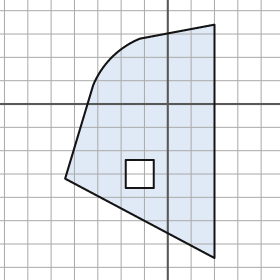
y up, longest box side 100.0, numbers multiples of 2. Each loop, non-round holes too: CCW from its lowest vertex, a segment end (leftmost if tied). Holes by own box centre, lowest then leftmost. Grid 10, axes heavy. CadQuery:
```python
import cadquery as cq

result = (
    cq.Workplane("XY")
    .moveTo(20.0, -66.0)
    .lineTo(20.0, 34.0)
    .lineTo(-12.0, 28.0)
    .threePointArc((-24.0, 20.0), (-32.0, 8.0))
    .lineTo(-44.0, -32.0)
    .close()
    .moveTo(-18.0, -36.0)
    .lineTo(-6.0, -36.0)
    .lineTo(-6.0, -24.0)
    .lineTo(-18.0, -24.0)
    .close()
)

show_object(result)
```